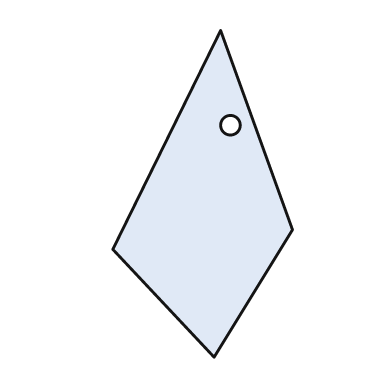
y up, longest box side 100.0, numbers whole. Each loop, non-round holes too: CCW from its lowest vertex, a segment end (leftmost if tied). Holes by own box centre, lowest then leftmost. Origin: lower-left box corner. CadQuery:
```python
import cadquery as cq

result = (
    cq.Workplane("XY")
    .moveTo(31.0, 0.0)
    .lineTo(55.0, 39.0)
    .lineTo(33.0, 100.0)
    .lineTo(0.0, 33.0)
    .close()
    .moveTo(36.0, 71.0)
    .circle(3.0)
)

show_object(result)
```